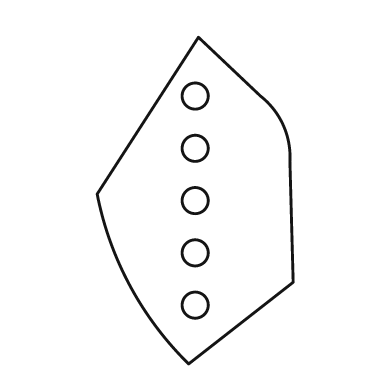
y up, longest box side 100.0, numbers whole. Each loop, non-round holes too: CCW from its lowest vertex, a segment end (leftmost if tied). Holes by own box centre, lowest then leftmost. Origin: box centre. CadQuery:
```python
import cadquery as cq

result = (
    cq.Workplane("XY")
    .moveTo(-2.0, -50.0)
    .lineTo(30.0, -25.0)
    .lineTo(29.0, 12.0)
    .threePointArc((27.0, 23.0), (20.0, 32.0))
    .lineTo(1.0, 50.0)
    .lineTo(-30.0, 2.0)
    .threePointArc((-20.0, -26.0), (-2.0, -50.0))
    .close()
    .moveTo(0.0, -32.0)
    .circle(4.0)
    .moveTo(0.0, -16.0)
    .circle(4.0)
    .moveTo(0.0, 0.0)
    .circle(4.0)
    .moveTo(0.0, 16.0)
    .circle(4.0)
    .moveTo(0.0, 32.0)
    .circle(4.0)
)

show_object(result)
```